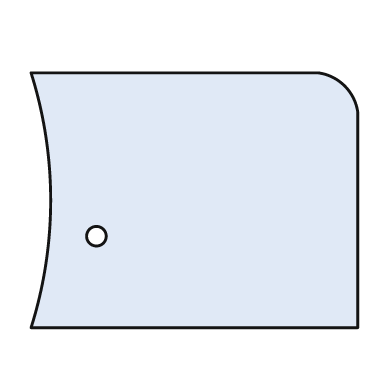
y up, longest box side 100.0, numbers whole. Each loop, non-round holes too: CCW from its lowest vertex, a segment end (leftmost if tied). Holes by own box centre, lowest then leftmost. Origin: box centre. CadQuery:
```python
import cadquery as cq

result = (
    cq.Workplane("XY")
    .moveTo(-50.0, -39.0)
    .lineTo(50.0, -39.0)
    .lineTo(50.0, 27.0)
    .threePointArc((46.0, 35.0), (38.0, 39.0))
    .lineTo(-50.0, 39.0)
    .threePointArc((-44.0, 0.0), (-50.0, -39.0))
    .close()
    .moveTo(-30.0, -11.0)
    .circle(3.0)
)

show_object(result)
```